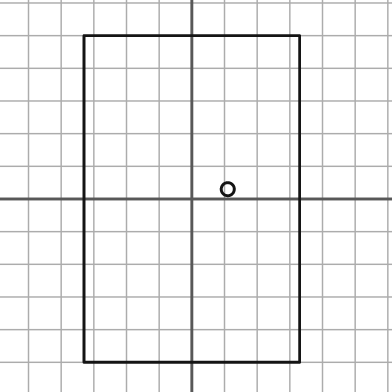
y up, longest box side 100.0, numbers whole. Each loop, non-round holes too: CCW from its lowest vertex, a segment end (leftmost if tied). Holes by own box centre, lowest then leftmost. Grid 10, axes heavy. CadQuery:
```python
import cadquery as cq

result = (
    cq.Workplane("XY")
    .moveTo(-33.0, -50.0)
    .lineTo(33.0, -50.0)
    .lineTo(33.0, 50.0)
    .lineTo(-33.0, 50.0)
    .close()
    .moveTo(11.0, 3.0)
    .circle(2.0)
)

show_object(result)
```